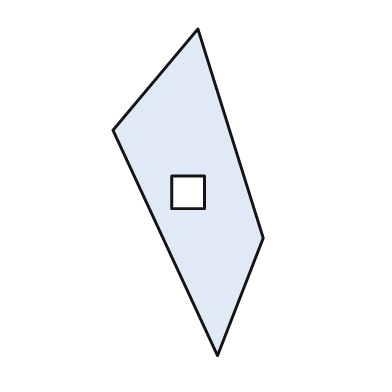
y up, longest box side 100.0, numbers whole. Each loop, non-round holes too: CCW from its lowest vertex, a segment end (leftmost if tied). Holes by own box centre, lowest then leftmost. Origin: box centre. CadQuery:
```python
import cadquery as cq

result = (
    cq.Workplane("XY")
    .moveTo(9.0, -50.0)
    .lineTo(23.0, -14.0)
    .lineTo(3.0, 50.0)
    .lineTo(-23.0, 19.0)
    .close()
    .moveTo(-5.0, -5.0)
    .lineTo(5.0, -5.0)
    .lineTo(5.0, 5.0)
    .lineTo(-5.0, 5.0)
    .close()
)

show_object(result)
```